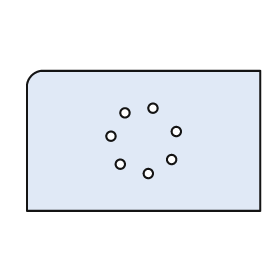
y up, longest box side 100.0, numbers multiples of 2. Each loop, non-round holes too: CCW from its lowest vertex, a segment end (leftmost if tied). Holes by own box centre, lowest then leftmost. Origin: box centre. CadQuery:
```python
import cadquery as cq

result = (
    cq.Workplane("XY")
    .moveTo(-50.0, -30.0)
    .lineTo(50.0, -30.0)
    .lineTo(50.0, 30.0)
    .lineTo(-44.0, 30.0)
    .threePointArc((-48.0, 28.0), (-50.0, 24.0))
    .close()
    .moveTo(2.0, -14.0)
    .circle(2.0)
    .moveTo(-10.0, -10.0)
    .circle(2.0)
    .moveTo(12.0, -8.0)
    .circle(2.0)
    .moveTo(-14.0, 2.0)
    .circle(2.0)
    .moveTo(14.0, 4.0)
    .circle(2.0)
    .moveTo(-8.0, 12.0)
    .circle(2.0)
    .moveTo(4.0, 14.0)
    .circle(2.0)
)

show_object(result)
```